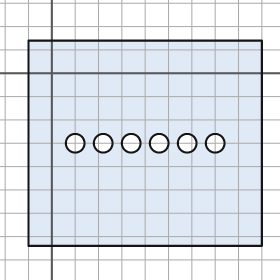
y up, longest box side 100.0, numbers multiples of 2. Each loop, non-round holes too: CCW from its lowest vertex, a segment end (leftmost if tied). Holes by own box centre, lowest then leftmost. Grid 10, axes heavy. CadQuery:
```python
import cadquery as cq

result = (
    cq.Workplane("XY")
    .moveTo(-10.0, -74.0)
    .lineTo(90.0, -74.0)
    .lineTo(90.0, 14.0)
    .lineTo(-10.0, 14.0)
    .close()
    .moveTo(10.0, -30.0)
    .circle(4.0)
    .moveTo(22.0, -30.0)
    .circle(4.0)
    .moveTo(34.0, -30.0)
    .circle(4.0)
    .moveTo(46.0, -30.0)
    .circle(4.0)
    .moveTo(58.0, -30.0)
    .circle(4.0)
    .moveTo(70.0, -30.0)
    .circle(4.0)
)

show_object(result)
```